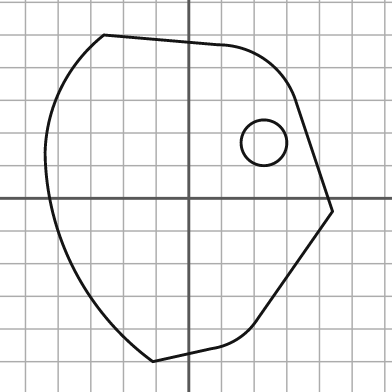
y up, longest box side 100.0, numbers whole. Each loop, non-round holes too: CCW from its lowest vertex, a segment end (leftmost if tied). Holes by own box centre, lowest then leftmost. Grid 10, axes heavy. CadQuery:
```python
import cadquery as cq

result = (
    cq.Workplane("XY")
    .moveTo(-11.0, -50.0)
    .lineTo(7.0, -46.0)
    .threePointArc((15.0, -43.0), (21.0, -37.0))
    .lineTo(44.0, -4.0)
    .lineTo(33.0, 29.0)
    .threePointArc((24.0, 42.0), (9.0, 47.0))
    .lineTo(-26.0, 50.0)
    .threePointArc((-39.0, 34.0), (-44.0, 14.0))
    .threePointArc((-35.0, -22.0), (-11.0, -50.0))
    .close()
    .moveTo(23.0, 17.0)
    .circle(7.0)
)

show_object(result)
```